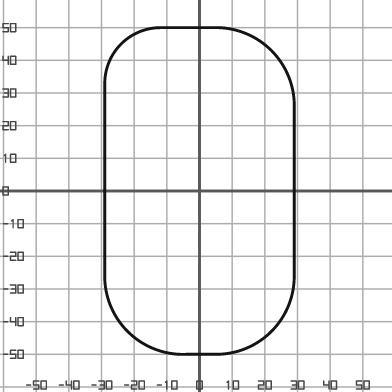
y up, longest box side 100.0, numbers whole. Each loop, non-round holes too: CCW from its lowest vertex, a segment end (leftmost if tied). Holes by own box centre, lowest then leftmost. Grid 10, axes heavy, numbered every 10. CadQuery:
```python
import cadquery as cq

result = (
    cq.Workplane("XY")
    .moveTo(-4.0, -50.0)
    .lineTo(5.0, -50.0)
    .threePointArc((22.0, -43.0), (29.0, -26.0))
    .lineTo(29.0, 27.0)
    .threePointArc((22.0, 43.0), (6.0, 50.0))
    .lineTo(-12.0, 50.0)
    .threePointArc((-24.0, 45.0), (-29.0, 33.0))
    .lineTo(-29.0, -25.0)
    .threePointArc((-22.0, -43.0), (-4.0, -50.0))
    .close()
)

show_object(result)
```